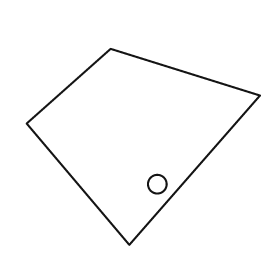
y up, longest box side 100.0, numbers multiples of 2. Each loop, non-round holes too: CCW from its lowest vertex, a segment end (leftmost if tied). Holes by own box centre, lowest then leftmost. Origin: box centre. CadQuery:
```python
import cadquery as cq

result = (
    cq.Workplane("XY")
    .moveTo(-6.0, -42.0)
    .lineTo(50.0, 22.0)
    .lineTo(-14.0, 42.0)
    .lineTo(-50.0, 10.0)
    .close()
    .moveTo(6.0, -16.0)
    .circle(4.0)
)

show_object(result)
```